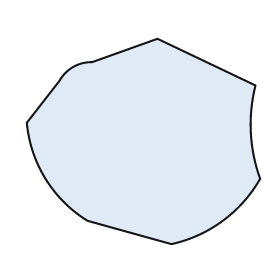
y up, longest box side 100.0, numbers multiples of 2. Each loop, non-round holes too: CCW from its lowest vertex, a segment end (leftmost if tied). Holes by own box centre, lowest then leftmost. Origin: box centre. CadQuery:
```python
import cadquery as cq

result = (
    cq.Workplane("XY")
    .moveTo(12.0, -44.0)
    .threePointArc((34.0, -34.0), (50.0, -16.0))
    .threePointArc((46.0, 4.0), (48.0, 24.0))
    .lineTo(6.0, 44.0)
    .lineTo(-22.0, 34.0)
    .threePointArc((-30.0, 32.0), (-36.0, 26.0))
    .lineTo(-50.0, 8.0)
    .threePointArc((-42.0, -16.0), (-24.0, -34.0))
    .close()
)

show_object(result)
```